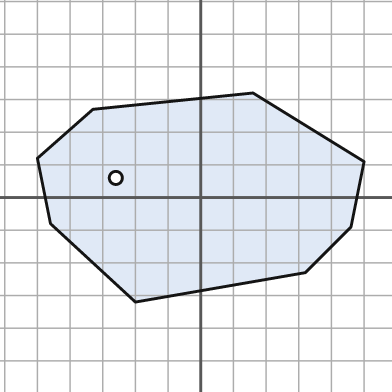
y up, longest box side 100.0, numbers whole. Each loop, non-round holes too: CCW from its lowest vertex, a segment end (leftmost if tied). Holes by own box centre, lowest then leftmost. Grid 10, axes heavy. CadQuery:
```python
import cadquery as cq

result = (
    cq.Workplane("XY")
    .moveTo(-20.0, -32.0)
    .lineTo(32.0, -23.0)
    .lineTo(46.0, -9.0)
    .lineTo(50.0, 11.0)
    .lineTo(16.0, 32.0)
    .lineTo(-33.0, 27.0)
    .lineTo(-50.0, 12.0)
    .lineTo(-46.0, -8.0)
    .close()
    .moveTo(-26.0, 6.0)
    .circle(2.0)
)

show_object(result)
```